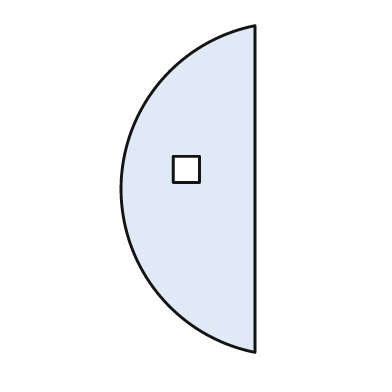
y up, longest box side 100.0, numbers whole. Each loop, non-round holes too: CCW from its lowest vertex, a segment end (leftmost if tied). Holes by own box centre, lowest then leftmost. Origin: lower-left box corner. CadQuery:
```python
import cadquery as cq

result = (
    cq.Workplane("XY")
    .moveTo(41.0, 0.0)
    .lineTo(41.0, 100.0)
    .threePointArc((0.0, 50.0), (41.0, 0.0))
    .close()
    .moveTo(16.0, 52.0)
    .lineTo(24.0, 52.0)
    .lineTo(24.0, 60.0)
    .lineTo(16.0, 60.0)
    .close()
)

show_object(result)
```